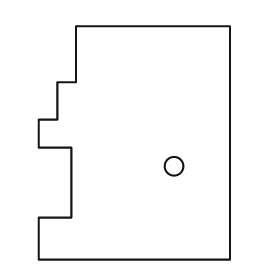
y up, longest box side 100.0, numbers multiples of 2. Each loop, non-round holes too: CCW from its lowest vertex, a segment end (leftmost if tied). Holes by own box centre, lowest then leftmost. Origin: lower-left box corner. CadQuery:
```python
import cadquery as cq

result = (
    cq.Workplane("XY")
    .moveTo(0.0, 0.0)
    .lineTo(82.0, 0.0)
    .lineTo(82.0, 100.0)
    .lineTo(16.0, 100.0)
    .lineTo(16.0, 76.0)
    .lineTo(8.0, 76.0)
    .lineTo(8.0, 60.0)
    .lineTo(0.0, 60.0)
    .lineTo(0.0, 48.0)
    .lineTo(14.0, 48.0)
    .lineTo(14.0, 18.0)
    .lineTo(0.0, 18.0)
    .close()
    .moveTo(58.0, 40.0)
    .circle(4.0)
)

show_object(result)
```